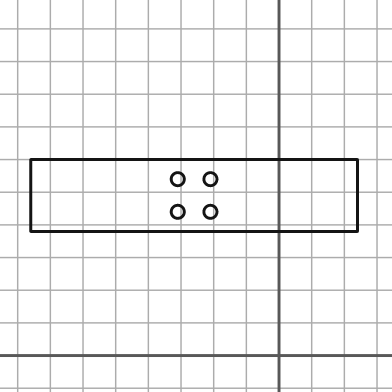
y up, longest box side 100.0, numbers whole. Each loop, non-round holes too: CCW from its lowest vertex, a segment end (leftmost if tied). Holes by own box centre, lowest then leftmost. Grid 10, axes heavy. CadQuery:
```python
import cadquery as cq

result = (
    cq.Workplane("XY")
    .moveTo(-76.0, 38.0)
    .lineTo(24.0, 38.0)
    .lineTo(24.0, 60.0)
    .lineTo(-76.0, 60.0)
    .close()
    .moveTo(-31.0, 44.0)
    .circle(2.0)
    .moveTo(-21.0, 44.0)
    .circle(2.0)
    .moveTo(-31.0, 54.0)
    .circle(2.0)
    .moveTo(-21.0, 54.0)
    .circle(2.0)
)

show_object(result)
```